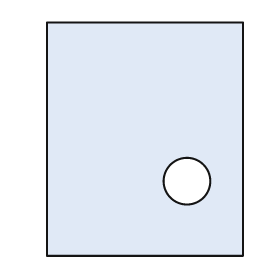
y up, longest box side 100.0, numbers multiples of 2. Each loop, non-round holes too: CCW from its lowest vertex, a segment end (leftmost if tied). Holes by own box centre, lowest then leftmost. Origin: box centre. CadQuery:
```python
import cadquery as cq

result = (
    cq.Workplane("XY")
    .moveTo(-42.0, -50.0)
    .lineTo(42.0, -50.0)
    .lineTo(42.0, 50.0)
    .lineTo(-42.0, 50.0)
    .close()
    .moveTo(18.0, -18.0)
    .circle(10.0)
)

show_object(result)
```